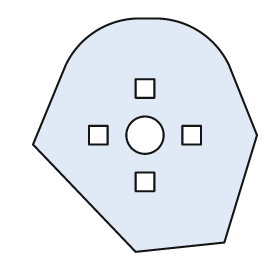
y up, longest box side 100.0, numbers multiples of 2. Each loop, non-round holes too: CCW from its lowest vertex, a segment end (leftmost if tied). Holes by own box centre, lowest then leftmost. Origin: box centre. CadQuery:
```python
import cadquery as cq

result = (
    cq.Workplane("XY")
    .moveTo(-4.0, -50.0)
    .lineTo(34.0, -46.0)
    .lineTo(48.0, 0.0)
    .lineTo(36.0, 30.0)
    .threePointArc((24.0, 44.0), (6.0, 50.0))
    .lineTo(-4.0, 50.0)
    .threePointArc((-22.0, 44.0), (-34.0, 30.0))
    .lineTo(-48.0, -4.0)
    .close()
    .moveTo(-4.0, -24.0)
    .lineTo(4.0, -24.0)
    .lineTo(4.0, -16.0)
    .lineTo(-4.0, -16.0)
    .close()
    .moveTo(-24.0, -4.0)
    .lineTo(-16.0, -4.0)
    .lineTo(-16.0, 4.0)
    .lineTo(-24.0, 4.0)
    .close()
    .moveTo(0.0, 0.0)
    .circle(8.0)
    .moveTo(16.0, -4.0)
    .lineTo(24.0, -4.0)
    .lineTo(24.0, 4.0)
    .lineTo(16.0, 4.0)
    .close()
    .moveTo(-4.0, 16.0)
    .lineTo(4.0, 16.0)
    .lineTo(4.0, 24.0)
    .lineTo(-4.0, 24.0)
    .close()
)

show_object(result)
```